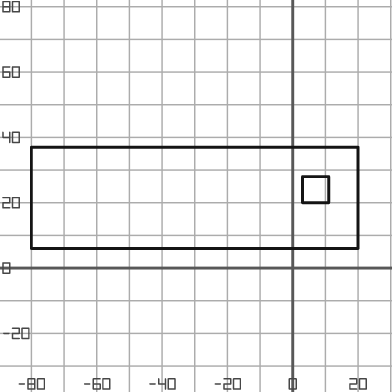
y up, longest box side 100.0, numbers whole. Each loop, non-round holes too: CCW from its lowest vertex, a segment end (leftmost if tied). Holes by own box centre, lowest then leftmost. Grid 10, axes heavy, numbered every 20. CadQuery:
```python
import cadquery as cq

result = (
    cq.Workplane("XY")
    .moveTo(-80.0, 6.0)
    .lineTo(20.0, 6.0)
    .lineTo(20.0, 37.0)
    .lineTo(-80.0, 37.0)
    .close()
    .moveTo(3.0, 20.0)
    .lineTo(11.0, 20.0)
    .lineTo(11.0, 28.0)
    .lineTo(3.0, 28.0)
    .close()
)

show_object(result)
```